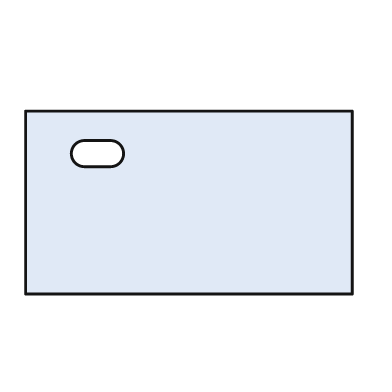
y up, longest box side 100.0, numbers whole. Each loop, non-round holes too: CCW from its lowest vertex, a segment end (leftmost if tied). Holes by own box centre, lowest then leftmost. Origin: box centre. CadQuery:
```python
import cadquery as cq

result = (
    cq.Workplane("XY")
    .moveTo(-50.0, -28.0)
    .lineTo(50.0, -28.0)
    .lineTo(50.0, 28.0)
    .lineTo(-50.0, 28.0)
    .close()
    .moveTo(-32.0, 11.0)
    .lineTo(-24.0, 11.0)
    .threePointArc((-20.0, 15.0), (-24.0, 19.0))
    .lineTo(-32.0, 19.0)
    .threePointArc((-36.0, 15.0), (-32.0, 11.0))
    .close()
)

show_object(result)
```